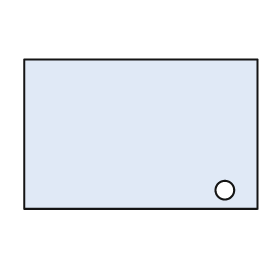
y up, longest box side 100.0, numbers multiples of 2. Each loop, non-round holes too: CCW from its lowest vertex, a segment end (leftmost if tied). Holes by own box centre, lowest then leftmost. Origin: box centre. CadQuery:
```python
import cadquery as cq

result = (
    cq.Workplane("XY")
    .moveTo(-50.0, -32.0)
    .lineTo(50.0, -32.0)
    .lineTo(50.0, 32.0)
    .lineTo(-50.0, 32.0)
    .close()
    .moveTo(36.0, -24.0)
    .circle(4.0)
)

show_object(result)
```